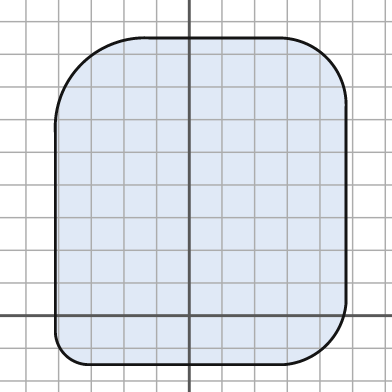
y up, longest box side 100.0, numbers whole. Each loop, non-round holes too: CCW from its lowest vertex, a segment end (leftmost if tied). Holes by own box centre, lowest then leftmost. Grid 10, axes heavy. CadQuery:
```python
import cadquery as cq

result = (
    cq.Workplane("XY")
    .moveTo(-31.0, -15.0)
    .lineTo(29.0, -15.0)
    .threePointArc((42.0, -9.0), (48.0, 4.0))
    .lineTo(48.0, 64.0)
    .threePointArc((42.0, 79.0), (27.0, 85.0))
    .lineTo(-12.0, 85.0)
    .threePointArc((-33.0, 77.0), (-41.0, 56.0))
    .lineTo(-41.0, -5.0)
    .threePointArc((-38.0, -12.0), (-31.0, -15.0))
    .close()
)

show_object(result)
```